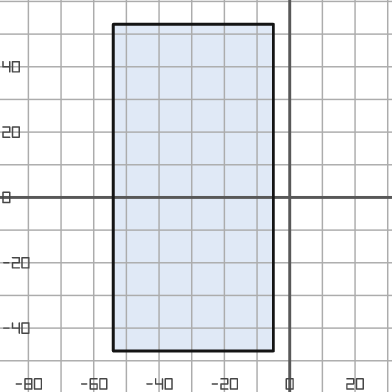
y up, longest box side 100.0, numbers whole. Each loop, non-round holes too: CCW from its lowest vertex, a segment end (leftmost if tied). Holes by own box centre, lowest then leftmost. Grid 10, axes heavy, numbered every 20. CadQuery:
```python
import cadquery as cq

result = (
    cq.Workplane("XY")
    .moveTo(-54.0, -47.0)
    .lineTo(-5.0, -47.0)
    .lineTo(-5.0, 53.0)
    .lineTo(-54.0, 53.0)
    .close()
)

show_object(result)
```